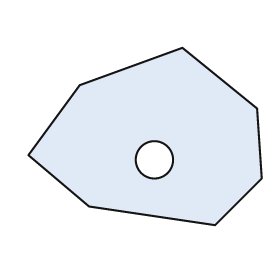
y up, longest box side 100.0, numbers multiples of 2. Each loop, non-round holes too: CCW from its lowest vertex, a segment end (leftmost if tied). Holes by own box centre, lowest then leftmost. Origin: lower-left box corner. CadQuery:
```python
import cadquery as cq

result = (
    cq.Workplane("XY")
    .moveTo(80.0, 0.0)
    .lineTo(100.0, 20.0)
    .lineTo(98.0, 50.0)
    .lineTo(66.0, 76.0)
    .lineTo(22.0, 60.0)
    .lineTo(0.0, 30.0)
    .lineTo(26.0, 8.0)
    .close()
    .moveTo(54.0, 28.0)
    .circle(8.0)
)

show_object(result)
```